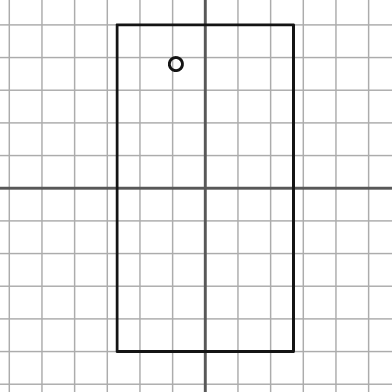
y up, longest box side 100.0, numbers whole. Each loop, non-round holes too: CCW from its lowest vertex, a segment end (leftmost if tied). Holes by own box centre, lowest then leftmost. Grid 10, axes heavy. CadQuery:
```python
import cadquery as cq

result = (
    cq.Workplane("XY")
    .moveTo(-27.0, -50.0)
    .lineTo(27.0, -50.0)
    .lineTo(27.0, 50.0)
    .lineTo(-27.0, 50.0)
    .close()
    .moveTo(-9.0, 38.0)
    .circle(2.0)
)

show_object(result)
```